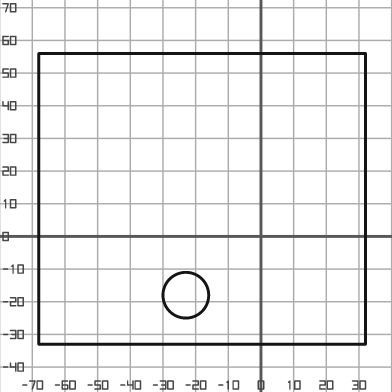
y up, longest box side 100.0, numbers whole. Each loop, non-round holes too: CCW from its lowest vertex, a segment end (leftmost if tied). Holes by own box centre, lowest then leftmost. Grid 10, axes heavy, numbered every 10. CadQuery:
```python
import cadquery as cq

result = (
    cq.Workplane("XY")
    .moveTo(-68.0, -33.0)
    .lineTo(32.0, -33.0)
    .lineTo(32.0, 56.0)
    .lineTo(-68.0, 56.0)
    .close()
    .moveTo(-23.0, -18.0)
    .circle(7.0)
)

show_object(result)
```